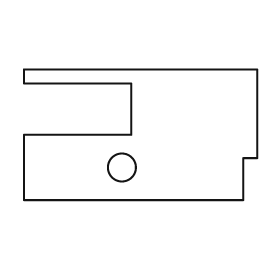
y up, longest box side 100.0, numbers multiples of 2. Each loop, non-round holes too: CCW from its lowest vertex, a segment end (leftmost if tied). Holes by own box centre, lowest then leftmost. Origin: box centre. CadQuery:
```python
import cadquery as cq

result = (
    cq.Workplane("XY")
    .moveTo(-50.0, -28.0)
    .lineTo(44.0, -28.0)
    .lineTo(44.0, -10.0)
    .lineTo(50.0, -10.0)
    .lineTo(50.0, 28.0)
    .lineTo(-50.0, 28.0)
    .lineTo(-50.0, 22.0)
    .lineTo(-4.0, 22.0)
    .lineTo(-4.0, 0.0)
    .lineTo(-50.0, 0.0)
    .close()
    .moveTo(-8.0, -14.0)
    .circle(6.0)
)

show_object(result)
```